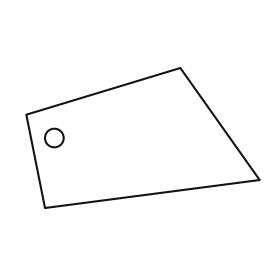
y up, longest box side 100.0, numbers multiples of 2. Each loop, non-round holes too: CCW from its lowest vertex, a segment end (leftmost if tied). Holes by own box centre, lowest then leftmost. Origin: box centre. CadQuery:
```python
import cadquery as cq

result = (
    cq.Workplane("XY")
    .moveTo(-42.0, -30.0)
    .lineTo(50.0, -18.0)
    .lineTo(16.0, 30.0)
    .lineTo(-50.0, 10.0)
    .close()
    .moveTo(-38.0, 0.0)
    .circle(4.0)
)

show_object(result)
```